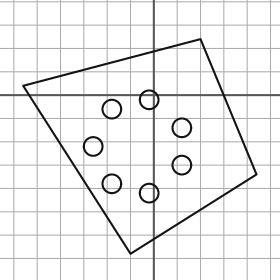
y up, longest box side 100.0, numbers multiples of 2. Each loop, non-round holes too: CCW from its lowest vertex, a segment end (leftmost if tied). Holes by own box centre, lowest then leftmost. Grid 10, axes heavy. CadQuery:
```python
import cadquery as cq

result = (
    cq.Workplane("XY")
    .moveTo(-10.0, -68.0)
    .lineTo(44.0, -34.0)
    .lineTo(20.0, 24.0)
    .lineTo(-56.0, 4.0)
    .close()
    .moveTo(-2.0, -42.0)
    .circle(4.0)
    .moveTo(-18.0, -38.0)
    .circle(4.0)
    .moveTo(12.0, -30.0)
    .circle(4.0)
    .moveTo(-26.0, -22.0)
    .circle(4.0)
    .moveTo(12.0, -14.0)
    .circle(4.0)
    .moveTo(-18.0, -6.0)
    .circle(4.0)
    .moveTo(-2.0, -2.0)
    .circle(4.0)
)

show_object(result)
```